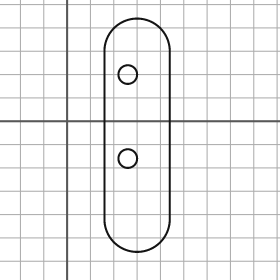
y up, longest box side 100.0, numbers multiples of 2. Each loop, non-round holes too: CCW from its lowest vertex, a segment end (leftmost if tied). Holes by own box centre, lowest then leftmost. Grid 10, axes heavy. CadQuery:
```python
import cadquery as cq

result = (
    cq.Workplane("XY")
    .moveTo(16.0, -42.0)
    .threePointArc((30.0, -56.0), (44.0, -42.0))
    .lineTo(44.0, 30.0)
    .threePointArc((30.0, 44.0), (16.0, 30.0))
    .close()
    .moveTo(26.0, -16.0)
    .circle(4.0)
    .moveTo(26.0, 20.0)
    .circle(4.0)
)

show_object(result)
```